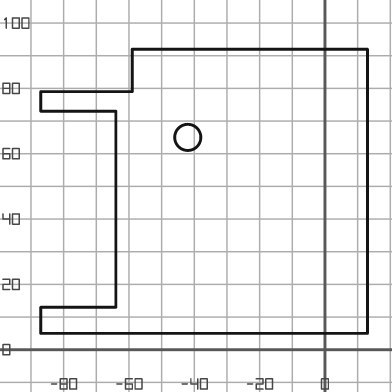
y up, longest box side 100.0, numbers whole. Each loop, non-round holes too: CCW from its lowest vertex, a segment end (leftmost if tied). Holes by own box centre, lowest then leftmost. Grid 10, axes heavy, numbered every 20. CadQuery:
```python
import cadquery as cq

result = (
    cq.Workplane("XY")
    .moveTo(-87.0, 5.0)
    .lineTo(13.0, 5.0)
    .lineTo(13.0, 92.0)
    .lineTo(-59.0, 92.0)
    .lineTo(-59.0, 79.0)
    .lineTo(-87.0, 79.0)
    .lineTo(-87.0, 73.0)
    .lineTo(-64.0, 73.0)
    .lineTo(-64.0, 13.0)
    .lineTo(-87.0, 13.0)
    .close()
    .moveTo(-42.0, 65.0)
    .circle(4.0)
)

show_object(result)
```